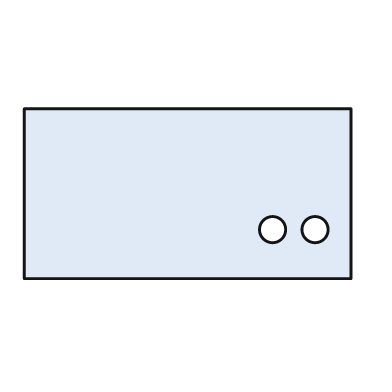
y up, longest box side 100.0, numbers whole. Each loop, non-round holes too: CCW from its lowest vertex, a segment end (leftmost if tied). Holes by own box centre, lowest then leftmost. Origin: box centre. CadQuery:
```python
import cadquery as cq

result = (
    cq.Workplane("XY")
    .moveTo(-50.0, -26.0)
    .lineTo(50.0, -26.0)
    .lineTo(50.0, 26.0)
    .lineTo(-50.0, 26.0)
    .close()
    .moveTo(26.0, -11.0)
    .circle(4.0)
    .moveTo(39.0, -11.0)
    .circle(4.0)
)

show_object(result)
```